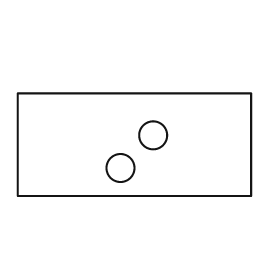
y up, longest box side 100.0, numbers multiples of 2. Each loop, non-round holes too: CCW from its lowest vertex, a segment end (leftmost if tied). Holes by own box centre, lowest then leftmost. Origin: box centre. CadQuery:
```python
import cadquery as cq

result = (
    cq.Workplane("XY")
    .moveTo(-50.0, -22.0)
    .lineTo(50.0, -22.0)
    .lineTo(50.0, 22.0)
    .lineTo(-50.0, 22.0)
    .close()
    .moveTo(-6.0, -10.0)
    .circle(6.0)
    .moveTo(8.0, 4.0)
    .circle(6.0)
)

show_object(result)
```